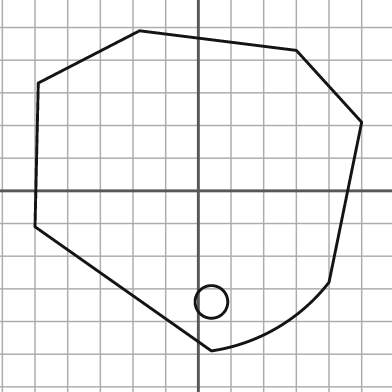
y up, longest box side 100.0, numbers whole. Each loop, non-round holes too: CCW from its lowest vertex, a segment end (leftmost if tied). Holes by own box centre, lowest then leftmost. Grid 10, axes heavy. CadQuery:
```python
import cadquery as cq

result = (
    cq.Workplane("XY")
    .moveTo(4.0, -49.0)
    .threePointArc((24.0, -42.0), (40.0, -28.0))
    .lineTo(50.0, 21.0)
    .lineTo(30.0, 43.0)
    .lineTo(-18.0, 49.0)
    .lineTo(-49.0, 33.0)
    .lineTo(-50.0, -11.0)
    .close()
    .moveTo(4.0, -34.0)
    .circle(5.0)
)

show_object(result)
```